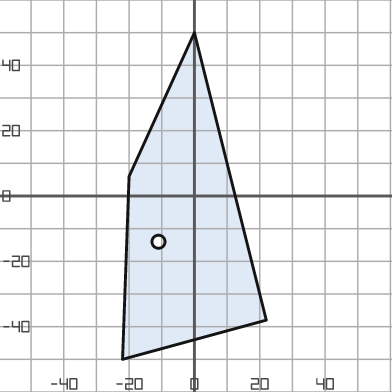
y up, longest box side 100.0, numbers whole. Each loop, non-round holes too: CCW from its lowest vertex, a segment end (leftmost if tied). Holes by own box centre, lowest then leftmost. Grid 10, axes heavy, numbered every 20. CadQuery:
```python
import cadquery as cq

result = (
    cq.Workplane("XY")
    .moveTo(-22.0, -50.0)
    .lineTo(22.0, -38.0)
    .lineTo(0.0, 50.0)
    .lineTo(-20.0, 6.0)
    .close()
    .moveTo(-11.0, -14.0)
    .circle(2.0)
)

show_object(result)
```